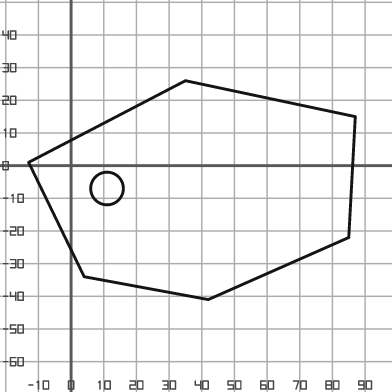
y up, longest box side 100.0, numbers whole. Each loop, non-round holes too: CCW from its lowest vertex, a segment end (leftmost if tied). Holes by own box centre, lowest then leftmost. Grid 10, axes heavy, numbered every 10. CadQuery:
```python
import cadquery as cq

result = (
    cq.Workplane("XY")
    .moveTo(42.0, -41.0)
    .lineTo(85.0, -22.0)
    .lineTo(87.0, 15.0)
    .lineTo(35.0, 26.0)
    .lineTo(-13.0, 1.0)
    .lineTo(4.0, -34.0)
    .close()
    .moveTo(11.0, -7.0)
    .circle(5.0)
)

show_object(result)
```